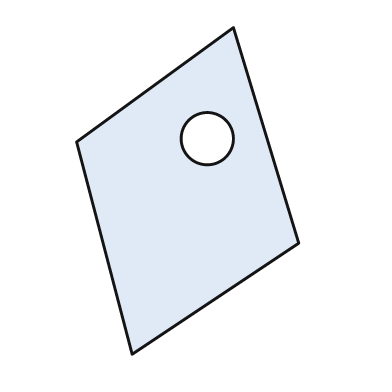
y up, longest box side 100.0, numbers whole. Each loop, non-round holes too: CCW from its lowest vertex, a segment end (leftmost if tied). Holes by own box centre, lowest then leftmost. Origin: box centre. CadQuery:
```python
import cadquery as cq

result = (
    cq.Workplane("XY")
    .moveTo(-17.0, -50.0)
    .lineTo(34.0, -16.0)
    .lineTo(14.0, 50.0)
    .lineTo(-34.0, 15.0)
    .close()
    .moveTo(6.0, 16.0)
    .circle(8.0)
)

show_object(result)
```